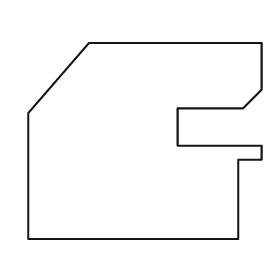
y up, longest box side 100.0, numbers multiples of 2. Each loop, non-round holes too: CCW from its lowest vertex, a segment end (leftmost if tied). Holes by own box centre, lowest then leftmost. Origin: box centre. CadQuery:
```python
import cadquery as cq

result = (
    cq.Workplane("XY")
    .moveTo(-50.0, -42.0)
    .lineTo(40.0, -42.0)
    .lineTo(40.0, -8.0)
    .lineTo(50.0, -8.0)
    .lineTo(50.0, -2.0)
    .lineTo(14.0, -2.0)
    .lineTo(14.0, 14.0)
    .lineTo(42.0, 14.0)
    .lineTo(50.0, 22.0)
    .lineTo(50.0, 42.0)
    .lineTo(-24.0, 42.0)
    .lineTo(-50.0, 12.0)
    .close()
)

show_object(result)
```